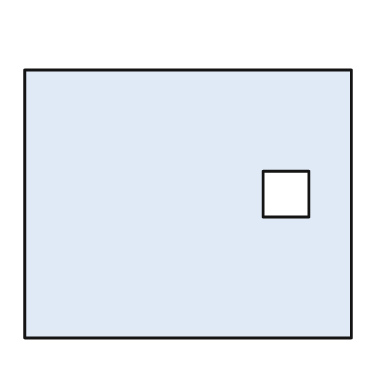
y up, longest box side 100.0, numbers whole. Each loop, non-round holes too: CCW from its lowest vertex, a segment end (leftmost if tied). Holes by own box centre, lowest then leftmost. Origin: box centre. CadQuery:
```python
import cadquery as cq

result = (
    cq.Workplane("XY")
    .moveTo(-50.0, -41.0)
    .lineTo(50.0, -41.0)
    .lineTo(50.0, 41.0)
    .lineTo(-50.0, 41.0)
    .close()
    .moveTo(23.0, -4.0)
    .lineTo(37.0, -4.0)
    .lineTo(37.0, 10.0)
    .lineTo(23.0, 10.0)
    .close()
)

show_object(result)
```